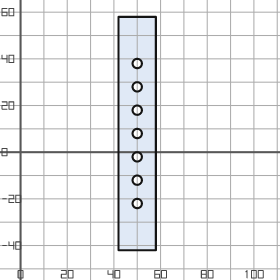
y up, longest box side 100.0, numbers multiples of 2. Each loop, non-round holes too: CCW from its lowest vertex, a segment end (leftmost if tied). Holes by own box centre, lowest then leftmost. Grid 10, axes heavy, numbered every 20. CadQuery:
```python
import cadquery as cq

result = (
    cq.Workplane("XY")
    .moveTo(42.0, -42.0)
    .lineTo(58.0, -42.0)
    .lineTo(58.0, 58.0)
    .lineTo(42.0, 58.0)
    .close()
    .moveTo(50.0, -22.0)
    .circle(2.0)
    .moveTo(50.0, -12.0)
    .circle(2.0)
    .moveTo(50.0, -2.0)
    .circle(2.0)
    .moveTo(50.0, 8.0)
    .circle(2.0)
    .moveTo(50.0, 18.0)
    .circle(2.0)
    .moveTo(50.0, 28.0)
    .circle(2.0)
    .moveTo(50.0, 38.0)
    .circle(2.0)
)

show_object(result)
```